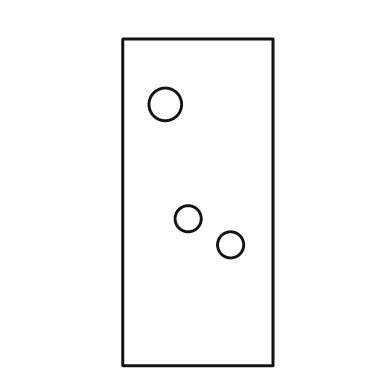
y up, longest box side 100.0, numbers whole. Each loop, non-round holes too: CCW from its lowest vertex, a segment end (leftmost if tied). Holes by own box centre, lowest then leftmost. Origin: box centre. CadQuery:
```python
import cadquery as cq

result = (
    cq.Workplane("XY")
    .moveTo(-23.0, -50.0)
    .lineTo(23.0, -50.0)
    .lineTo(23.0, 50.0)
    .lineTo(-23.0, 50.0)
    .close()
    .moveTo(10.0, -13.0)
    .circle(4.0)
    .moveTo(-3.0, -5.0)
    .circle(4.0)
    .moveTo(-10.0, 30.0)
    .circle(5.0)
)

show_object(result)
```